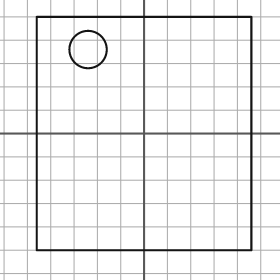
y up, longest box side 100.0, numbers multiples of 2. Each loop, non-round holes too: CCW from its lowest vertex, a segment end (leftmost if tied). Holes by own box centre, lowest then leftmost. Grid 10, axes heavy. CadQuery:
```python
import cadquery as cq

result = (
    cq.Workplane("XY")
    .moveTo(-46.0, -50.0)
    .lineTo(46.0, -50.0)
    .lineTo(46.0, 50.0)
    .lineTo(-46.0, 50.0)
    .close()
    .moveTo(-24.0, 36.0)
    .circle(8.0)
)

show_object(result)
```